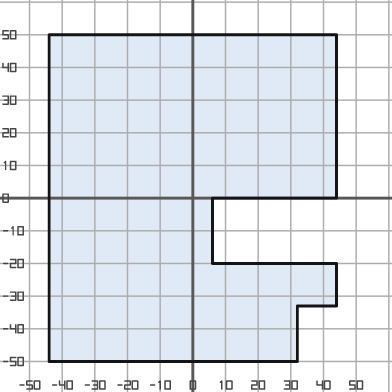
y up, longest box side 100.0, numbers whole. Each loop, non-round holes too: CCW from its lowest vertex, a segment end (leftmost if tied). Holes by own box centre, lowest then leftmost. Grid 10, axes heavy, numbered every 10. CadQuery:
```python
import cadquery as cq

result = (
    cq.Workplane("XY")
    .moveTo(-44.0, -50.0)
    .lineTo(32.0, -50.0)
    .lineTo(32.0, -33.0)
    .lineTo(44.0, -33.0)
    .lineTo(44.0, -20.0)
    .lineTo(6.0, -20.0)
    .lineTo(6.0, 0.0)
    .lineTo(44.0, 0.0)
    .lineTo(44.0, 50.0)
    .lineTo(-44.0, 50.0)
    .close()
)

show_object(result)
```